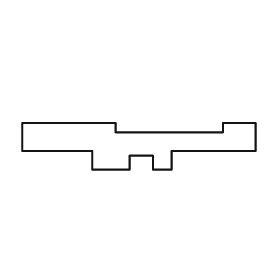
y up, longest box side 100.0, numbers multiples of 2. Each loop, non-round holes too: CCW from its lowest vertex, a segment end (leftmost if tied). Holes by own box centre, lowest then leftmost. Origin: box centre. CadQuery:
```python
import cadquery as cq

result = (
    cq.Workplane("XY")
    .moveTo(-20.0, -10.0)
    .lineTo(-4.0, -10.0)
    .lineTo(-4.0, -4.0)
    .lineTo(6.0, -4.0)
    .lineTo(6.0, -10.0)
    .lineTo(14.0, -10.0)
    .lineTo(14.0, -2.0)
    .lineTo(50.0, -2.0)
    .lineTo(50.0, 10.0)
    .lineTo(36.0, 10.0)
    .lineTo(36.0, 6.0)
    .lineTo(-10.0, 6.0)
    .lineTo(-10.0, 10.0)
    .lineTo(-50.0, 10.0)
    .lineTo(-50.0, -2.0)
    .lineTo(-20.0, -2.0)
    .close()
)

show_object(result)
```